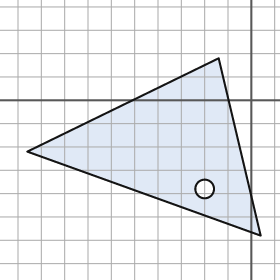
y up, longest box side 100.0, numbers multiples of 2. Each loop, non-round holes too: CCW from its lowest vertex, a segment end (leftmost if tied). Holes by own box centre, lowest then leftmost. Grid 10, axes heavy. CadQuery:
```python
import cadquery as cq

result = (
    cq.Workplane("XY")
    .moveTo(4.0, -58.0)
    .lineTo(-14.0, 18.0)
    .lineTo(-96.0, -22.0)
    .close()
    .moveTo(-20.0, -38.0)
    .circle(4.0)
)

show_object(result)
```